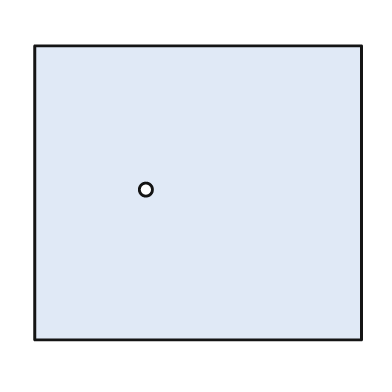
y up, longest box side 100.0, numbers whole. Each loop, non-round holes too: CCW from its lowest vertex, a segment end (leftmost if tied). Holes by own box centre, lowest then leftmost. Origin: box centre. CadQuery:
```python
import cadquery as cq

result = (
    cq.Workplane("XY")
    .moveTo(-50.0, -45.0)
    .lineTo(50.0, -45.0)
    .lineTo(50.0, 45.0)
    .lineTo(-50.0, 45.0)
    .close()
    .moveTo(-16.0, 1.0)
    .circle(2.0)
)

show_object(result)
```